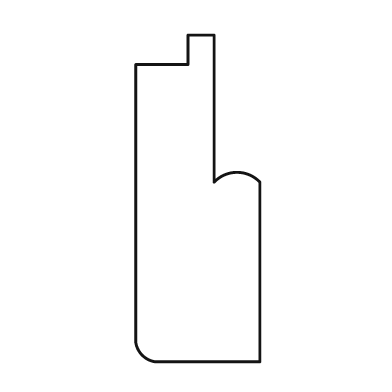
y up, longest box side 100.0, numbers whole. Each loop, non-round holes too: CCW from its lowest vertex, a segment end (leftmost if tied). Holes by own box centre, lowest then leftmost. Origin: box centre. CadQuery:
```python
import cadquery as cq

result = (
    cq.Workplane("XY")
    .moveTo(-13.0, -50.0)
    .lineTo(19.0, -50.0)
    .lineTo(19.0, 5.0)
    .threePointArc((12.0, 8.0), (5.0, 5.0))
    .lineTo(5.0, 50.0)
    .lineTo(-3.0, 50.0)
    .lineTo(-3.0, 41.0)
    .lineTo(-19.0, 41.0)
    .lineTo(-19.0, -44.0)
    .threePointArc((-17.0, -48.0), (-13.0, -50.0))
    .close()
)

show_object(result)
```